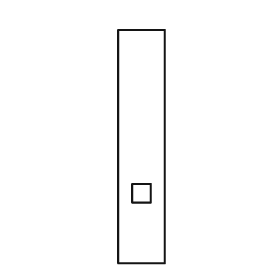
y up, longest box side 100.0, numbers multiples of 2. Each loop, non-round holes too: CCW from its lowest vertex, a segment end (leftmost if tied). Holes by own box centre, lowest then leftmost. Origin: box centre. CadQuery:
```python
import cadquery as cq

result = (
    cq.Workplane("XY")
    .moveTo(-10.0, -50.0)
    .lineTo(10.0, -50.0)
    .lineTo(10.0, 50.0)
    .lineTo(-10.0, 50.0)
    .close()
    .moveTo(-4.0, -24.0)
    .lineTo(4.0, -24.0)
    .lineTo(4.0, -16.0)
    .lineTo(-4.0, -16.0)
    .close()
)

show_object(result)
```